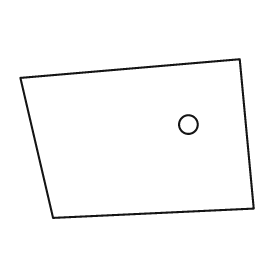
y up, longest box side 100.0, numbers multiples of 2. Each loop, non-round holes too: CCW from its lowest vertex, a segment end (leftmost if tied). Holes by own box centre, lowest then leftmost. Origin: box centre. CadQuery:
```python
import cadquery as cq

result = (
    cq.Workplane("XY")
    .moveTo(-36.0, -34.0)
    .lineTo(50.0, -30.0)
    .lineTo(44.0, 34.0)
    .lineTo(-50.0, 26.0)
    .close()
    .moveTo(22.0, 6.0)
    .circle(4.0)
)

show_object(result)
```